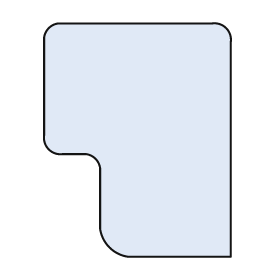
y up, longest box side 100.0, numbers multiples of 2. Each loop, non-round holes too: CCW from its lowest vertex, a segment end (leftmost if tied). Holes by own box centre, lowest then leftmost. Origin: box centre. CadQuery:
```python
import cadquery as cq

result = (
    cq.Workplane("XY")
    .moveTo(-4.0, -50.0)
    .lineTo(40.0, -50.0)
    .lineTo(40.0, 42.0)
    .threePointArc((38.0, 48.0), (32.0, 50.0))
    .lineTo(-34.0, 50.0)
    .threePointArc((-38.0, 48.0), (-40.0, 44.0))
    .lineTo(-40.0, 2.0)
    .threePointArc((-38.0, -4.0), (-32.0, -6.0))
    .lineTo(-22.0, -6.0)
    .threePointArc((-18.0, -8.0), (-16.0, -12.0))
    .lineTo(-16.0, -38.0)
    .threePointArc((-12.0, -46.0), (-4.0, -50.0))
    .close()
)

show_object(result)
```